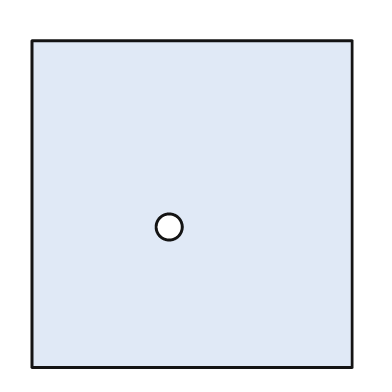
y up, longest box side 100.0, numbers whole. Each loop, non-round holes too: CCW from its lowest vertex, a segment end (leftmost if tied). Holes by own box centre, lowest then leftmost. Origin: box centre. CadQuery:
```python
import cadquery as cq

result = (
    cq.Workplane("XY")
    .moveTo(-49.0, -50.0)
    .lineTo(49.0, -50.0)
    .lineTo(49.0, 50.0)
    .lineTo(-49.0, 50.0)
    .close()
    .moveTo(-7.0, -7.0)
    .circle(4.0)
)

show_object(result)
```